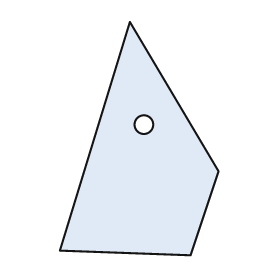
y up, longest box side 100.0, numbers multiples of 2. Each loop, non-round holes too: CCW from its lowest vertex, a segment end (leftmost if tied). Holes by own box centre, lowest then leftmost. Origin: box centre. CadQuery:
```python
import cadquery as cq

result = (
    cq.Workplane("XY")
    .moveTo(22.0, -50.0)
    .lineTo(34.0, -14.0)
    .lineTo(-4.0, 50.0)
    .lineTo(-34.0, -48.0)
    .close()
    .moveTo(2.0, 6.0)
    .circle(4.0)
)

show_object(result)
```